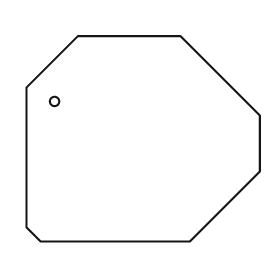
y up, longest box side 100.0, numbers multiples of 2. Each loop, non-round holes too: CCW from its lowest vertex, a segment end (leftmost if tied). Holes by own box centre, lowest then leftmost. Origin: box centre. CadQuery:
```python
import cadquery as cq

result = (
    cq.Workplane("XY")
    .moveTo(-44.0, -44.0)
    .lineTo(20.0, -44.0)
    .lineTo(50.0, -14.0)
    .lineTo(50.0, 10.0)
    .lineTo(16.0, 44.0)
    .lineTo(-28.0, 44.0)
    .lineTo(-50.0, 22.0)
    .lineTo(-50.0, -38.0)
    .close()
    .moveTo(-38.0, 16.0)
    .circle(2.0)
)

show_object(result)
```